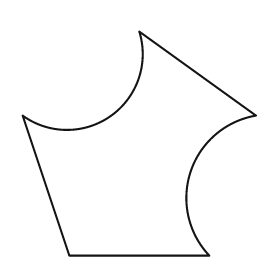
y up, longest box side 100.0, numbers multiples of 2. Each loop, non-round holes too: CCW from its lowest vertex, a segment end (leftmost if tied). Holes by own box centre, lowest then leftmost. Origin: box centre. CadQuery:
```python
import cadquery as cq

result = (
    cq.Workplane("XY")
    .moveTo(-30.0, -48.0)
    .lineTo(30.0, -48.0)
    .threePointArc((22.0, -12.0), (50.0, 12.0))
    .lineTo(0.0, 48.0)
    .threePointArc((-12.0, 12.0), (-50.0, 12.0))
    .close()
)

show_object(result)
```